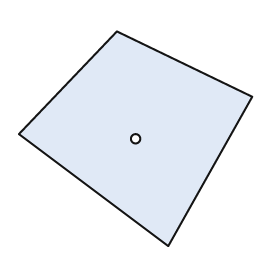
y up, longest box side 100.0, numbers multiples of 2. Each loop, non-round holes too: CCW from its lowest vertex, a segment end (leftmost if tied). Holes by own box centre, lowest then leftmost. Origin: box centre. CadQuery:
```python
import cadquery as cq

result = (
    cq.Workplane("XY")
    .moveTo(14.0, -46.0)
    .lineTo(50.0, 18.0)
    .lineTo(-8.0, 46.0)
    .lineTo(-50.0, 2.0)
    .close()
    .moveTo(0.0, 0.0)
    .circle(2.0)
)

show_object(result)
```